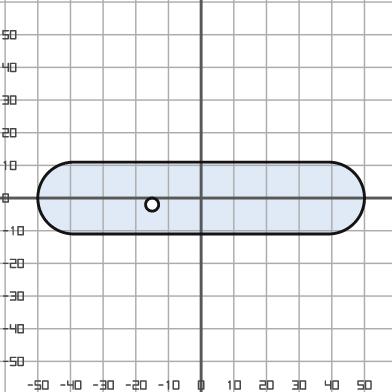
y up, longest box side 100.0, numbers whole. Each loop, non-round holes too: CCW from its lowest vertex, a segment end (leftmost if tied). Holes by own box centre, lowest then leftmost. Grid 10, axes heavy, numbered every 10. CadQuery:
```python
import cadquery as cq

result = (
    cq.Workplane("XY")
    .moveTo(-39.0, -11.0)
    .lineTo(39.0, -11.0)
    .threePointArc((50.0, 0.0), (39.0, 11.0))
    .lineTo(-39.0, 11.0)
    .threePointArc((-50.0, 0.0), (-39.0, -11.0))
    .close()
    .moveTo(-15.0, -2.0)
    .circle(2.0)
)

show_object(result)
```